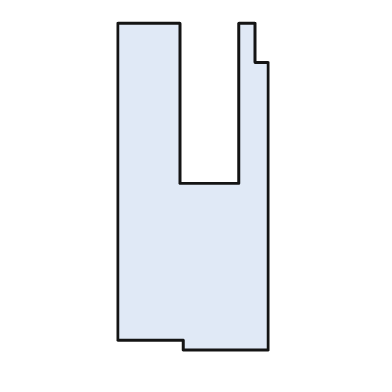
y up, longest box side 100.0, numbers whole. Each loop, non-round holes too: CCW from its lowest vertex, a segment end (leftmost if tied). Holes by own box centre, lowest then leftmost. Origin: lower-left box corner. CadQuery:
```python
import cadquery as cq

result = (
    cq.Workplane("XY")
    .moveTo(20.0, 0.0)
    .lineTo(46.0, 0.0)
    .lineTo(46.0, 88.0)
    .lineTo(42.0, 88.0)
    .lineTo(42.0, 100.0)
    .lineTo(37.0, 100.0)
    .lineTo(37.0, 51.0)
    .lineTo(19.0, 51.0)
    .lineTo(19.0, 100.0)
    .lineTo(0.0, 100.0)
    .lineTo(0.0, 3.0)
    .lineTo(20.0, 3.0)
    .close()
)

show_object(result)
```